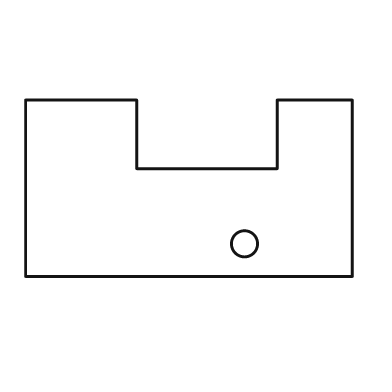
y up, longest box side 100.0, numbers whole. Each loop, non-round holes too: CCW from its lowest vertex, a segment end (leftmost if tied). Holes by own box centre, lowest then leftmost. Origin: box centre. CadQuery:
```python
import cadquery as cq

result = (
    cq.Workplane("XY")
    .moveTo(-50.0, -27.0)
    .lineTo(50.0, -27.0)
    .lineTo(50.0, 27.0)
    .lineTo(27.0, 27.0)
    .lineTo(27.0, 6.0)
    .lineTo(-16.0, 6.0)
    .lineTo(-16.0, 27.0)
    .lineTo(-50.0, 27.0)
    .close()
    .moveTo(17.0, -17.0)
    .circle(4.0)
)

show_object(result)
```